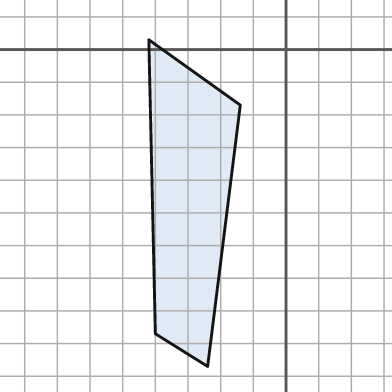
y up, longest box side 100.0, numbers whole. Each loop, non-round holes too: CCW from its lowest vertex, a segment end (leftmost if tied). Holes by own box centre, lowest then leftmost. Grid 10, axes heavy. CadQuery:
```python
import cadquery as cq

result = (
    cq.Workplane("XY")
    .moveTo(-24.0, -97.0)
    .lineTo(-14.0, -17.0)
    .lineTo(-42.0, 3.0)
    .lineTo(-40.0, -87.0)
    .close()
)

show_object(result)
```